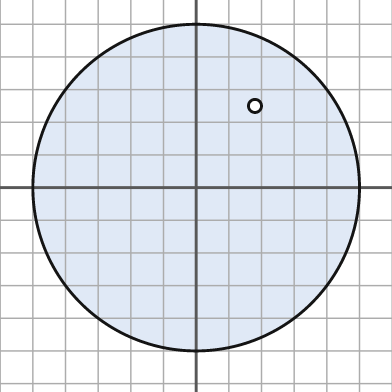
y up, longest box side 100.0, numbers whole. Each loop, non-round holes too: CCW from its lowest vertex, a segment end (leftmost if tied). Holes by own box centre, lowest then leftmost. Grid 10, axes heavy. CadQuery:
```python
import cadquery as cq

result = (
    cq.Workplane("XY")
    .moveTo(0.0, 0.0)
    .circle(50.0)
    .moveTo(18.0, 25.0)
    .circle(2.0)
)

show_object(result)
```